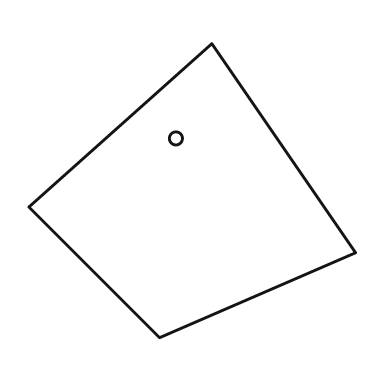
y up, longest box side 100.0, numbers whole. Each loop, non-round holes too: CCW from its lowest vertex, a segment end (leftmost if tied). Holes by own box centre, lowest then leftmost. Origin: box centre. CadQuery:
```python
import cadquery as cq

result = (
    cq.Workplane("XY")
    .moveTo(-10.0, -45.0)
    .lineTo(50.0, -19.0)
    .lineTo(6.0, 45.0)
    .lineTo(-50.0, -5.0)
    .close()
    .moveTo(-5.0, 16.0)
    .circle(2.0)
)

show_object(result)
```